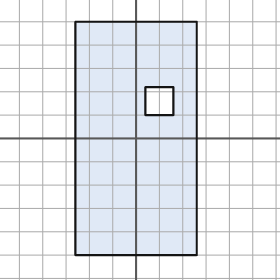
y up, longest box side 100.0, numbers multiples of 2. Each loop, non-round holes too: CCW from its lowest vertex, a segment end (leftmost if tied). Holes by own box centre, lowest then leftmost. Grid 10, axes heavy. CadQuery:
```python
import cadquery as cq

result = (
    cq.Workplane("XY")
    .moveTo(-26.0, -50.0)
    .lineTo(26.0, -50.0)
    .lineTo(26.0, 50.0)
    .lineTo(-26.0, 50.0)
    .close()
    .moveTo(4.0, 10.0)
    .lineTo(16.0, 10.0)
    .lineTo(16.0, 22.0)
    .lineTo(4.0, 22.0)
    .close()
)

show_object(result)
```